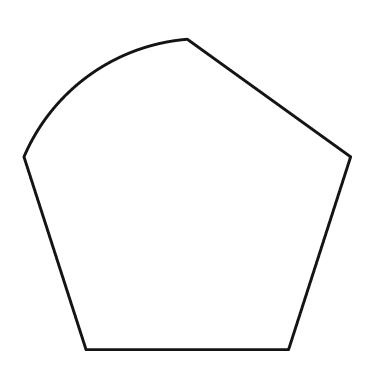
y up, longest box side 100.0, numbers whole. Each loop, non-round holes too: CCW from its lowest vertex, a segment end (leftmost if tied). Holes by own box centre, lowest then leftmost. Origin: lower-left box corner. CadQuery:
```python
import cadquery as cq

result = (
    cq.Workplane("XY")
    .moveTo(19.0, 0.0)
    .lineTo(81.0, 0.0)
    .lineTo(100.0, 59.0)
    .lineTo(50.0, 95.0)
    .threePointArc((20.0, 84.0), (0.0, 59.0))
    .close()
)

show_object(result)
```